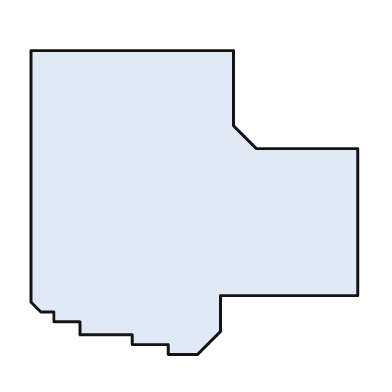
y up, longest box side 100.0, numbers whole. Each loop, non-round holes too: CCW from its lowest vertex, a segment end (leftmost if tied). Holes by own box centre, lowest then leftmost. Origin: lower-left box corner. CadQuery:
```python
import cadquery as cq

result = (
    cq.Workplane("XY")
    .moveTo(42.0, 0.0)
    .lineTo(51.0, 0.0)
    .lineTo(58.0, 7.0)
    .lineTo(58.0, 18.0)
    .lineTo(100.0, 18.0)
    .lineTo(100.0, 63.0)
    .lineTo(69.0, 63.0)
    .lineTo(62.0, 70.0)
    .lineTo(62.0, 93.0)
    .lineTo(0.0, 93.0)
    .lineTo(0.0, 16.0)
    .lineTo(3.0, 13.0)
    .lineTo(7.0, 13.0)
    .lineTo(7.0, 10.0)
    .lineTo(15.0, 10.0)
    .lineTo(15.0, 6.0)
    .lineTo(31.0, 6.0)
    .lineTo(31.0, 3.0)
    .lineTo(42.0, 3.0)
    .close()
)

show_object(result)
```